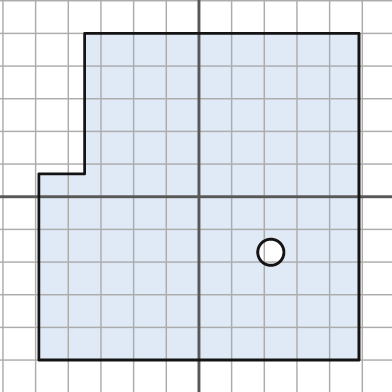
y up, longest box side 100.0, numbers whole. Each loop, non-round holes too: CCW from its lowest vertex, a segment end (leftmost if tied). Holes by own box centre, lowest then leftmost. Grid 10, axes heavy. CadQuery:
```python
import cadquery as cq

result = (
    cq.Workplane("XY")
    .moveTo(-49.0, -50.0)
    .lineTo(49.0, -50.0)
    .lineTo(49.0, 50.0)
    .lineTo(-35.0, 50.0)
    .lineTo(-35.0, 7.0)
    .lineTo(-49.0, 7.0)
    .close()
    .moveTo(22.0, -17.0)
    .circle(4.0)
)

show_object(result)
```